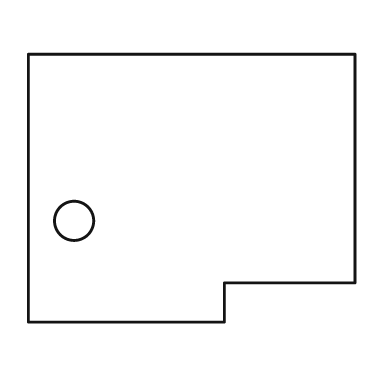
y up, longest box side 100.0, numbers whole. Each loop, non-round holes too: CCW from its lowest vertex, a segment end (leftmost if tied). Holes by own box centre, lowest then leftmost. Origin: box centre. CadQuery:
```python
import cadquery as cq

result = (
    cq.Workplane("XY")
    .moveTo(-50.0, -41.0)
    .lineTo(10.0, -41.0)
    .lineTo(10.0, -29.0)
    .lineTo(50.0, -29.0)
    .lineTo(50.0, 41.0)
    .lineTo(-50.0, 41.0)
    .close()
    .moveTo(-36.0, -10.0)
    .circle(6.0)
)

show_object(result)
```